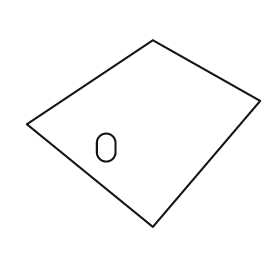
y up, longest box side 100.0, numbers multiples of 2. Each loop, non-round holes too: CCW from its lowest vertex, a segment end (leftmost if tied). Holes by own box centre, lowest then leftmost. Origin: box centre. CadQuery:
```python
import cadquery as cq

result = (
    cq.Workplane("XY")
    .moveTo(4.0, -40.0)
    .lineTo(50.0, 14.0)
    .lineTo(4.0, 40.0)
    .lineTo(-50.0, 4.0)
    .close()
    .moveTo(-20.0, -8.0)
    .threePointArc((-16.0, -12.0), (-12.0, -8.0))
    .lineTo(-12.0, -4.0)
    .threePointArc((-16.0, 0.0), (-20.0, -4.0))
    .close()
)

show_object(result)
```